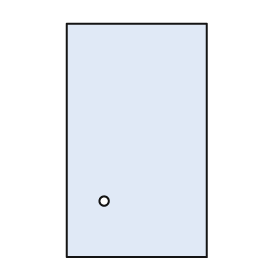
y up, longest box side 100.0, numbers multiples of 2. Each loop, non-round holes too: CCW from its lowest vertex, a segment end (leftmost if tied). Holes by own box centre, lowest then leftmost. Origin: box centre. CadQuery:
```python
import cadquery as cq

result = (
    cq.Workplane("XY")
    .moveTo(-30.0, -50.0)
    .lineTo(30.0, -50.0)
    .lineTo(30.0, 50.0)
    .lineTo(-30.0, 50.0)
    .close()
    .moveTo(-14.0, -26.0)
    .circle(2.0)
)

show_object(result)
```